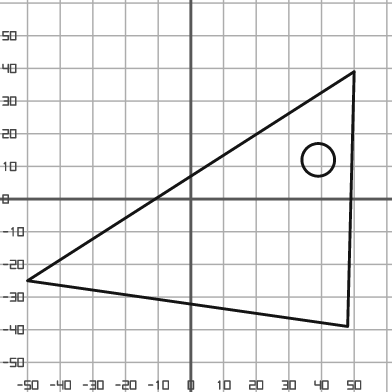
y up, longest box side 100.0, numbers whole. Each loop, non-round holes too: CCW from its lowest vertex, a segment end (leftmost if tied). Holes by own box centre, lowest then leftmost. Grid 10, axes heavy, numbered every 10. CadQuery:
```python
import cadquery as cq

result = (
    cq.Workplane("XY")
    .moveTo(48.0, -39.0)
    .lineTo(50.0, 39.0)
    .lineTo(-50.0, -25.0)
    .close()
    .moveTo(39.0, 12.0)
    .circle(5.0)
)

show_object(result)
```